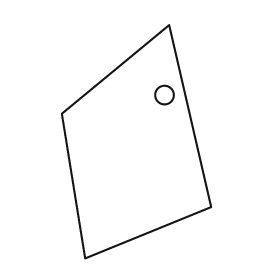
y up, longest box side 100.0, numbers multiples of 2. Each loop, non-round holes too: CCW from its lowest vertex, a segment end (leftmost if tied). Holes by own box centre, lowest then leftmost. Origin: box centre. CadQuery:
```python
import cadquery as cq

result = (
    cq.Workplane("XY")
    .moveTo(-22.0, -50.0)
    .lineTo(32.0, -28.0)
    .lineTo(14.0, 50.0)
    .lineTo(-32.0, 12.0)
    .close()
    .moveTo(12.0, 20.0)
    .circle(4.0)
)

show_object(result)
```